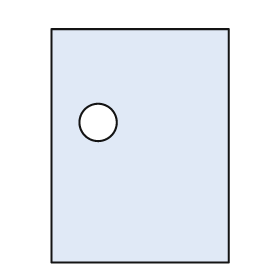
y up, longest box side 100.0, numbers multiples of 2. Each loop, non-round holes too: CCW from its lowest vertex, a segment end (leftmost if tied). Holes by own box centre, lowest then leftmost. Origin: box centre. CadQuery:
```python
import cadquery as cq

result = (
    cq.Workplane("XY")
    .moveTo(-38.0, -50.0)
    .lineTo(38.0, -50.0)
    .lineTo(38.0, 50.0)
    .lineTo(-38.0, 50.0)
    .close()
    .moveTo(-18.0, 10.0)
    .circle(8.0)
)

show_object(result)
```